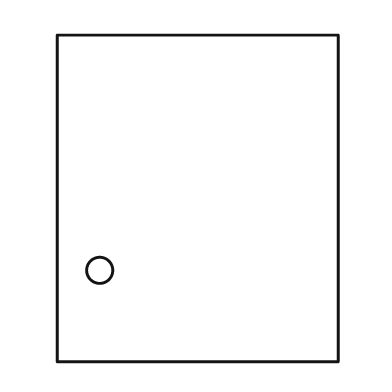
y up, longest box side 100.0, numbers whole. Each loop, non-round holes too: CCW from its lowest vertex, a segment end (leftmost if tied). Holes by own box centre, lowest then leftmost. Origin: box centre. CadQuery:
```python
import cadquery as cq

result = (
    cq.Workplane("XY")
    .moveTo(-43.0, -50.0)
    .lineTo(43.0, -50.0)
    .lineTo(43.0, 50.0)
    .lineTo(-43.0, 50.0)
    .close()
    .moveTo(-30.0, -22.0)
    .circle(4.0)
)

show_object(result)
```